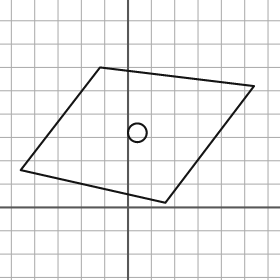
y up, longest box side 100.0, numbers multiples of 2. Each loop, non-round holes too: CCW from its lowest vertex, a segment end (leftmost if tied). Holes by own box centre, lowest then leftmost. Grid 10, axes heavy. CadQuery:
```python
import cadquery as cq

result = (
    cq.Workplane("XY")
    .moveTo(16.0, 2.0)
    .lineTo(54.0, 52.0)
    .lineTo(-12.0, 60.0)
    .lineTo(-46.0, 16.0)
    .close()
    .moveTo(4.0, 32.0)
    .circle(4.0)
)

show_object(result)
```